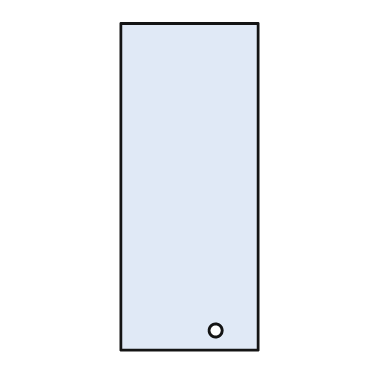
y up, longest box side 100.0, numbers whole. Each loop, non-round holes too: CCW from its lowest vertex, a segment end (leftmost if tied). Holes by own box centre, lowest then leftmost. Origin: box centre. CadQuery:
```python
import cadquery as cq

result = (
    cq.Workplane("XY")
    .moveTo(-21.0, -50.0)
    .lineTo(21.0, -50.0)
    .lineTo(21.0, 50.0)
    .lineTo(-21.0, 50.0)
    .close()
    .moveTo(8.0, -44.0)
    .circle(2.0)
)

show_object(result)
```